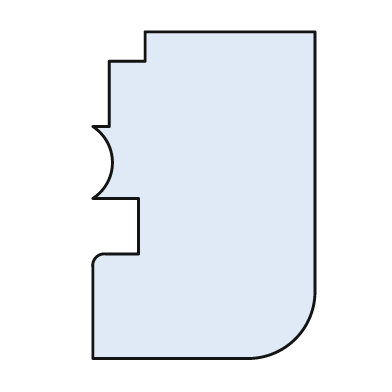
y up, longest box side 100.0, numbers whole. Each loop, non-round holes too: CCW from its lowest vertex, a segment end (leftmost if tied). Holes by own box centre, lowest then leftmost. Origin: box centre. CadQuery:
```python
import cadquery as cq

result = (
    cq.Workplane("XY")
    .moveTo(-34.0, -50.0)
    .lineTo(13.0, -50.0)
    .threePointArc((28.0, -44.0), (34.0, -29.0))
    .lineTo(34.0, 50.0)
    .lineTo(-18.0, 50.0)
    .lineTo(-18.0, 41.0)
    .lineTo(-29.0, 41.0)
    .lineTo(-29.0, 21.0)
    .lineTo(-34.0, 21.0)
    .threePointArc((-28.0, 10.0), (-34.0, -1.0))
    .lineTo(-20.0, -1.0)
    .lineTo(-20.0, -18.0)
    .lineTo(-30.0, -18.0)
    .threePointArc((-33.0, -19.0), (-34.0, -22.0))
    .close()
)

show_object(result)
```